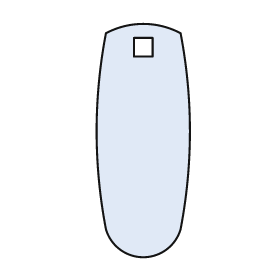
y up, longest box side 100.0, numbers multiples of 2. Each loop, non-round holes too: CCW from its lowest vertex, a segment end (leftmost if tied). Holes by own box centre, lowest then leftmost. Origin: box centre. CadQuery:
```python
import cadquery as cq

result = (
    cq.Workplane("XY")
    .moveTo(-16.0, -38.0)
    .threePointArc((0.0, -50.0), (16.0, -38.0))
    .threePointArc((20.0, 4.0), (16.0, 46.0))
    .threePointArc((0.0, 50.0), (-16.0, 46.0))
    .threePointArc((-20.0, 4.0), (-16.0, -38.0))
    .close()
    .moveTo(-4.0, 36.0)
    .lineTo(4.0, 36.0)
    .lineTo(4.0, 44.0)
    .lineTo(-4.0, 44.0)
    .close()
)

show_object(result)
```